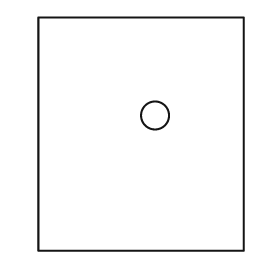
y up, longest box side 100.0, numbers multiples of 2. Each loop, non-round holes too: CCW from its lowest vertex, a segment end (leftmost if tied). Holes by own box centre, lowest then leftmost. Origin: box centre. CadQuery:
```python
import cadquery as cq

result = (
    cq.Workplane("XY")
    .moveTo(-44.0, -50.0)
    .lineTo(44.0, -50.0)
    .lineTo(44.0, 50.0)
    .lineTo(-44.0, 50.0)
    .close()
    .moveTo(6.0, 8.0)
    .circle(6.0)
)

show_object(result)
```